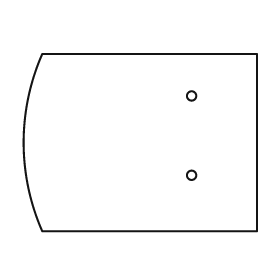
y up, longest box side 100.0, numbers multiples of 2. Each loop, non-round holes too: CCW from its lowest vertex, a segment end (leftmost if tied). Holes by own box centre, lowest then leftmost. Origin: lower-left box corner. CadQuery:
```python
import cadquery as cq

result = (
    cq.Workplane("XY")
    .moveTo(8.0, 0.0)
    .lineTo(100.0, 0.0)
    .lineTo(100.0, 76.0)
    .lineTo(8.0, 76.0)
    .threePointArc((0.0, 38.0), (8.0, 0.0))
    .close()
    .moveTo(72.0, 24.0)
    .circle(2.0)
    .moveTo(72.0, 58.0)
    .circle(2.0)
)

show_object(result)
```